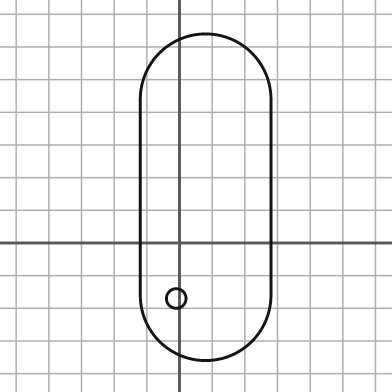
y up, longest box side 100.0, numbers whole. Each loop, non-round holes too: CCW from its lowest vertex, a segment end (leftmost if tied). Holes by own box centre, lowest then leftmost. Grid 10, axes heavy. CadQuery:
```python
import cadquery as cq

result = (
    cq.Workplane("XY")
    .moveTo(-12.0, -16.0)
    .threePointArc((8.0, -36.0), (28.0, -16.0))
    .lineTo(28.0, 44.0)
    .threePointArc((8.0, 64.0), (-12.0, 44.0))
    .close()
    .moveTo(-1.0, -17.0)
    .circle(3.0)
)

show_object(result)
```